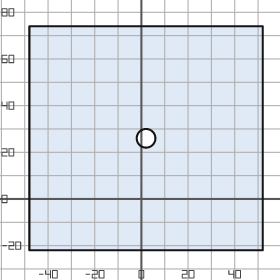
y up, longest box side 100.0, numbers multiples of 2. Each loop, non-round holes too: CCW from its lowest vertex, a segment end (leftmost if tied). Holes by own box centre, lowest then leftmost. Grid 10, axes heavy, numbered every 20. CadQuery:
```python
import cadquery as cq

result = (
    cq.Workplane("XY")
    .moveTo(-48.0, -22.0)
    .lineTo(52.0, -22.0)
    .lineTo(52.0, 74.0)
    .lineTo(-48.0, 74.0)
    .close()
    .moveTo(2.0, 26.0)
    .circle(4.0)
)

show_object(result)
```